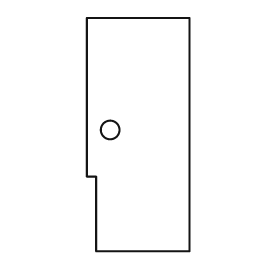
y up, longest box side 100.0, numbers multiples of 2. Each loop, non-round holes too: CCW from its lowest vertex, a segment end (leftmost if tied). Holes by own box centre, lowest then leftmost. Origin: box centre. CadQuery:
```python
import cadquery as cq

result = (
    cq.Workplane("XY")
    .moveTo(-18.0, -50.0)
    .lineTo(22.0, -50.0)
    .lineTo(22.0, 50.0)
    .lineTo(-22.0, 50.0)
    .lineTo(-22.0, -18.0)
    .lineTo(-18.0, -18.0)
    .close()
    .moveTo(-12.0, 2.0)
    .circle(4.0)
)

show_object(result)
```